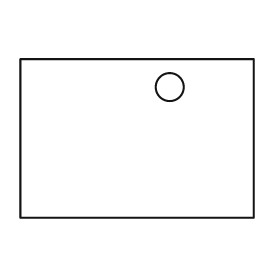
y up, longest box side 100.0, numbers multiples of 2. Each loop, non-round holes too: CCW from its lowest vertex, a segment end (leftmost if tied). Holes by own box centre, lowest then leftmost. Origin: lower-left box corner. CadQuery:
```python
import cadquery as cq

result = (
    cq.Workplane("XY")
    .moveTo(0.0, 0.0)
    .lineTo(100.0, 0.0)
    .lineTo(100.0, 68.0)
    .lineTo(0.0, 68.0)
    .close()
    .moveTo(64.0, 56.0)
    .circle(6.0)
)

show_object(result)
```